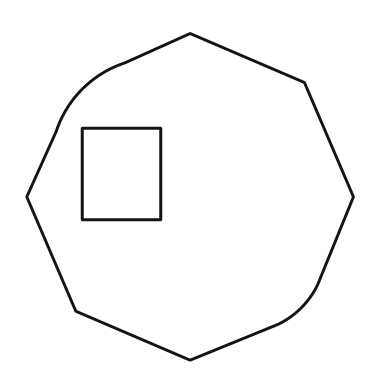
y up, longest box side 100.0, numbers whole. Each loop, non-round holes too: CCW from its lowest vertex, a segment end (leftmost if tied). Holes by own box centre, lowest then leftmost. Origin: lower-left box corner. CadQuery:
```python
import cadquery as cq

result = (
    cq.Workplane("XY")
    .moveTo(50.0, 0.0)
    .lineTo(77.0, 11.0)
    .threePointArc((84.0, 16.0), (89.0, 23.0))
    .lineTo(100.0, 50.0)
    .lineTo(85.0, 85.0)
    .lineTo(50.0, 100.0)
    .lineTo(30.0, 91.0)
    .threePointArc((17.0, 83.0), (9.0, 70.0))
    .lineTo(0.0, 50.0)
    .lineTo(15.0, 15.0)
    .close()
    .moveTo(17.0, 43.0)
    .lineTo(41.0, 43.0)
    .lineTo(41.0, 71.0)
    .lineTo(17.0, 71.0)
    .close()
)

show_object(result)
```